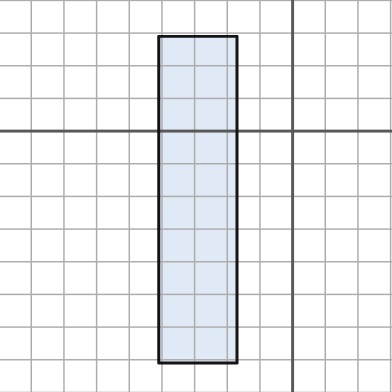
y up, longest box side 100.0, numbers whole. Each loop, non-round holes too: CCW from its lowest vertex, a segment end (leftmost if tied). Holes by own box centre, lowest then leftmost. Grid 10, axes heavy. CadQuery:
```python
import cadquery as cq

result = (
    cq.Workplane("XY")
    .moveTo(-41.0, -71.0)
    .lineTo(-17.0, -71.0)
    .lineTo(-17.0, 29.0)
    .lineTo(-41.0, 29.0)
    .close()
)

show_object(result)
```